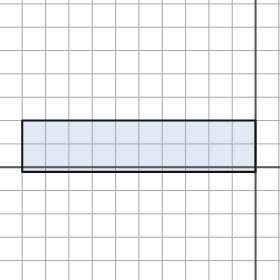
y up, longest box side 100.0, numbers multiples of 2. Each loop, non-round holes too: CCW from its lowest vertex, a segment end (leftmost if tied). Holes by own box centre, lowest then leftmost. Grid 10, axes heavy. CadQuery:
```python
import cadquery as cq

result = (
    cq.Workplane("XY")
    .moveTo(-100.0, -2.0)
    .lineTo(0.0, -2.0)
    .lineTo(0.0, 20.0)
    .lineTo(-100.0, 20.0)
    .close()
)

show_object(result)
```